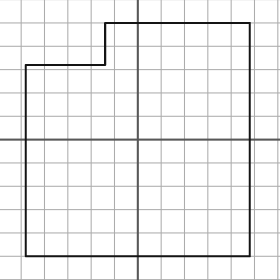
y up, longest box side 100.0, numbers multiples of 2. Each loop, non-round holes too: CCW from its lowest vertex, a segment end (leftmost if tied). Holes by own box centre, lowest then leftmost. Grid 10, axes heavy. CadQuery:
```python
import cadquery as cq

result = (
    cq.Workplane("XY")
    .moveTo(-48.0, -50.0)
    .lineTo(48.0, -50.0)
    .lineTo(48.0, 50.0)
    .lineTo(-14.0, 50.0)
    .lineTo(-14.0, 32.0)
    .lineTo(-48.0, 32.0)
    .close()
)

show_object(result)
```